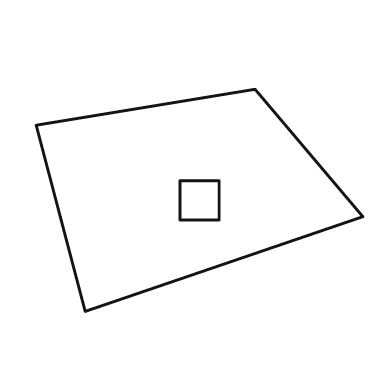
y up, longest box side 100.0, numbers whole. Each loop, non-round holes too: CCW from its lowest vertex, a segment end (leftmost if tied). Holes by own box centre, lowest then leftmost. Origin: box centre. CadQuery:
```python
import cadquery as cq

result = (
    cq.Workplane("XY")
    .moveTo(-35.0, -34.0)
    .lineTo(50.0, -5.0)
    .lineTo(17.0, 34.0)
    .lineTo(-50.0, 23.0)
    .close()
    .moveTo(-6.0, -6.0)
    .lineTo(6.0, -6.0)
    .lineTo(6.0, 6.0)
    .lineTo(-6.0, 6.0)
    .close()
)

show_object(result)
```